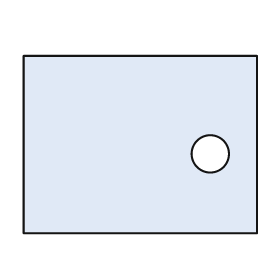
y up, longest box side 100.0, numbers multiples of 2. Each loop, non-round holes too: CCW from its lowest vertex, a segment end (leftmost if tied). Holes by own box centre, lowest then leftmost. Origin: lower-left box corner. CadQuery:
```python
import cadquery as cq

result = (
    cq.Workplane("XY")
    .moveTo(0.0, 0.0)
    .lineTo(100.0, 0.0)
    .lineTo(100.0, 76.0)
    .lineTo(0.0, 76.0)
    .close()
    .moveTo(80.0, 34.0)
    .circle(8.0)
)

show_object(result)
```